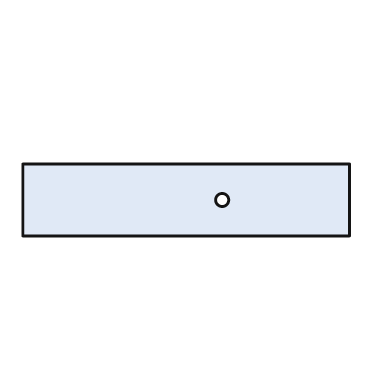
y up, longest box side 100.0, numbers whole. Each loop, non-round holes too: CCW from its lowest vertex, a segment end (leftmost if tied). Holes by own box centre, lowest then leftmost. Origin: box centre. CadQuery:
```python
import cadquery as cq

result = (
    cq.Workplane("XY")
    .moveTo(-50.0, -11.0)
    .lineTo(50.0, -11.0)
    .lineTo(50.0, 11.0)
    .lineTo(-50.0, 11.0)
    .close()
    .moveTo(11.0, 0.0)
    .circle(2.0)
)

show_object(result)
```